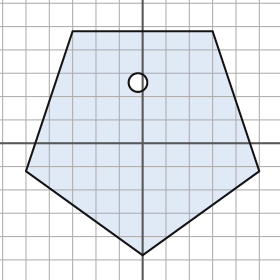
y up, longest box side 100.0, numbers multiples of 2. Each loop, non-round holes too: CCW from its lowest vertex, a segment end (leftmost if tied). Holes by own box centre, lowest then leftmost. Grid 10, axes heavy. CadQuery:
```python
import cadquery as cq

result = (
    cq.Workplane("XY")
    .moveTo(0.0, -48.0)
    .lineTo(50.0, -12.0)
    .lineTo(30.0, 48.0)
    .lineTo(-30.0, 48.0)
    .lineTo(-50.0, -12.0)
    .close()
    .moveTo(-2.0, 26.0)
    .circle(4.0)
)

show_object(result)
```